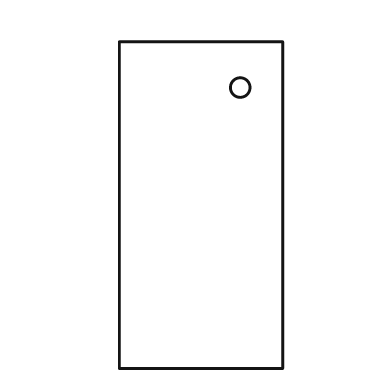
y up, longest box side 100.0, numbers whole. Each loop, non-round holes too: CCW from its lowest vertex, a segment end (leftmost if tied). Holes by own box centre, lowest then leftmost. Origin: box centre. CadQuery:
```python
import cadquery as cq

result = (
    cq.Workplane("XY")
    .moveTo(-25.0, -50.0)
    .lineTo(25.0, -50.0)
    .lineTo(25.0, 50.0)
    .lineTo(-25.0, 50.0)
    .close()
    .moveTo(12.0, 36.0)
    .circle(3.0)
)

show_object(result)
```